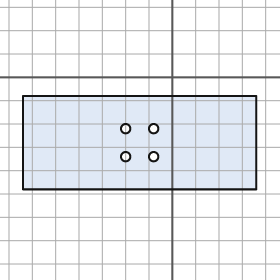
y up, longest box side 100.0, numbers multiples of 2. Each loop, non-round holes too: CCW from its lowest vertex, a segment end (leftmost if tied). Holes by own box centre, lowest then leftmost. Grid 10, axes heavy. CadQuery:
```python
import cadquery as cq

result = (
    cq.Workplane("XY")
    .moveTo(-64.0, -48.0)
    .lineTo(36.0, -48.0)
    .lineTo(36.0, -8.0)
    .lineTo(-64.0, -8.0)
    .close()
    .moveTo(-20.0, -34.0)
    .circle(2.0)
    .moveTo(-8.0, -34.0)
    .circle(2.0)
    .moveTo(-20.0, -22.0)
    .circle(2.0)
    .moveTo(-8.0, -22.0)
    .circle(2.0)
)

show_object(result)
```